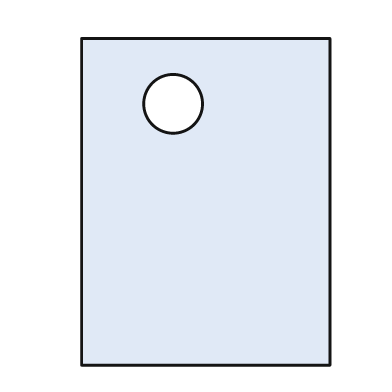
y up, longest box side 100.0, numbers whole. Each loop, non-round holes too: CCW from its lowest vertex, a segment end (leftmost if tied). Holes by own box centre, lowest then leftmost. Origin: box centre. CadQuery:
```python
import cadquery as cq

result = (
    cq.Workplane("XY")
    .moveTo(-38.0, -50.0)
    .lineTo(38.0, -50.0)
    .lineTo(38.0, 50.0)
    .lineTo(-38.0, 50.0)
    .close()
    .moveTo(-10.0, 30.0)
    .circle(9.0)
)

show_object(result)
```